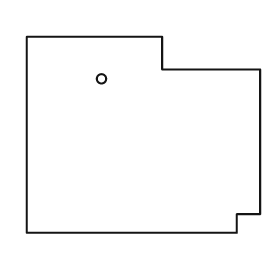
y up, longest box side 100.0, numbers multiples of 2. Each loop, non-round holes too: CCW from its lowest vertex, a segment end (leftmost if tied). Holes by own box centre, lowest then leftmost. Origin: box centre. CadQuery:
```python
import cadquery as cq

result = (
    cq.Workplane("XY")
    .moveTo(-50.0, -42.0)
    .lineTo(40.0, -42.0)
    .lineTo(40.0, -34.0)
    .lineTo(50.0, -34.0)
    .lineTo(50.0, 28.0)
    .lineTo(8.0, 28.0)
    .lineTo(8.0, 42.0)
    .lineTo(-50.0, 42.0)
    .close()
    .moveTo(-18.0, 24.0)
    .circle(2.0)
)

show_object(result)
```